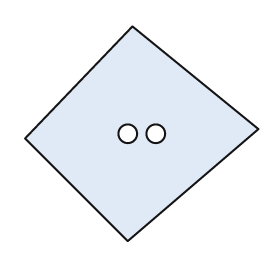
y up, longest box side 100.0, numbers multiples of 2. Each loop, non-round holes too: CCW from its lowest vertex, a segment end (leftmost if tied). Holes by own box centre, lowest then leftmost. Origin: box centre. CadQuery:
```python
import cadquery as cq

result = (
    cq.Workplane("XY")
    .moveTo(-6.0, -46.0)
    .lineTo(50.0, 2.0)
    .lineTo(-4.0, 46.0)
    .lineTo(-50.0, -2.0)
    .close()
    .moveTo(-6.0, 0.0)
    .circle(4.0)
    .moveTo(6.0, 0.0)
    .circle(4.0)
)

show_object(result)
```